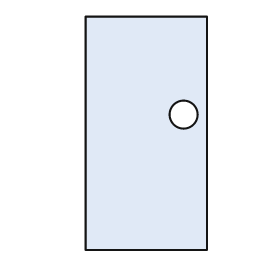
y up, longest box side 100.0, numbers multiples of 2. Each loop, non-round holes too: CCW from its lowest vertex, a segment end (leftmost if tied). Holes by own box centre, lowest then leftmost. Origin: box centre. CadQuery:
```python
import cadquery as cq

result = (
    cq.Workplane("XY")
    .moveTo(-26.0, -50.0)
    .lineTo(26.0, -50.0)
    .lineTo(26.0, 50.0)
    .lineTo(-26.0, 50.0)
    .close()
    .moveTo(16.0, 8.0)
    .circle(6.0)
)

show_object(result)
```